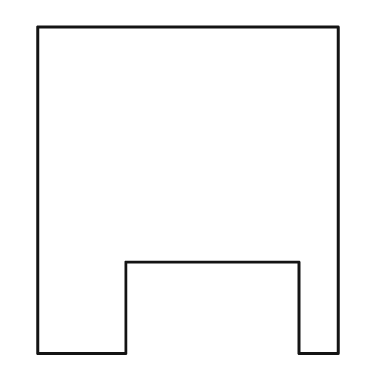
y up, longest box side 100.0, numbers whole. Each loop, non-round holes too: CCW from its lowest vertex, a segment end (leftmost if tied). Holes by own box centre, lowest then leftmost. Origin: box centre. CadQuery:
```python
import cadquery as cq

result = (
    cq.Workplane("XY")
    .moveTo(-46.0, -50.0)
    .lineTo(-19.0, -50.0)
    .lineTo(-19.0, -22.0)
    .lineTo(34.0, -22.0)
    .lineTo(34.0, -50.0)
    .lineTo(46.0, -50.0)
    .lineTo(46.0, 50.0)
    .lineTo(-46.0, 50.0)
    .close()
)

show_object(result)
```